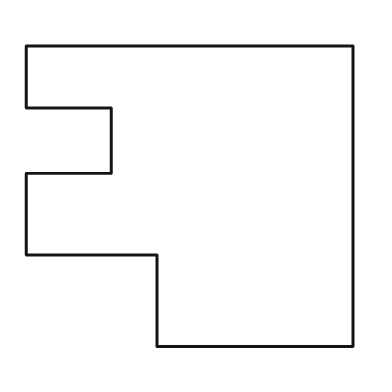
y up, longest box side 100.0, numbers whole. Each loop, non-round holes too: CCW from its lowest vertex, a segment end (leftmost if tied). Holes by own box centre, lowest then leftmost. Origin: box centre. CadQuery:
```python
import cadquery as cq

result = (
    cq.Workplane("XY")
    .moveTo(-10.0, -46.0)
    .lineTo(50.0, -46.0)
    .lineTo(50.0, 46.0)
    .lineTo(-50.0, 46.0)
    .lineTo(-50.0, 27.0)
    .lineTo(-24.0, 27.0)
    .lineTo(-24.0, 7.0)
    .lineTo(-50.0, 7.0)
    .lineTo(-50.0, -18.0)
    .lineTo(-10.0, -18.0)
    .close()
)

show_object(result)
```